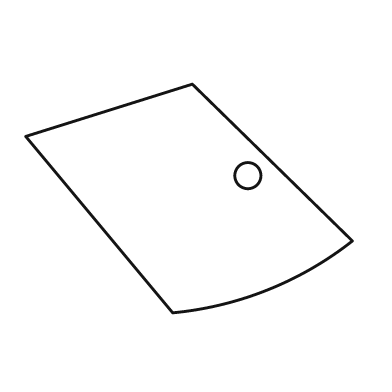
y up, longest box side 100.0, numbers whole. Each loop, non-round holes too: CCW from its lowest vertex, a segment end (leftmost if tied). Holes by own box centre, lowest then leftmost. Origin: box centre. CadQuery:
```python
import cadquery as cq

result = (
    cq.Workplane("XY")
    .moveTo(-5.0, -35.0)
    .threePointArc((24.0, -28.0), (50.0, -13.0))
    .lineTo(1.0, 35.0)
    .lineTo(-50.0, 19.0)
    .close()
    .moveTo(18.0, 7.0)
    .circle(4.0)
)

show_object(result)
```